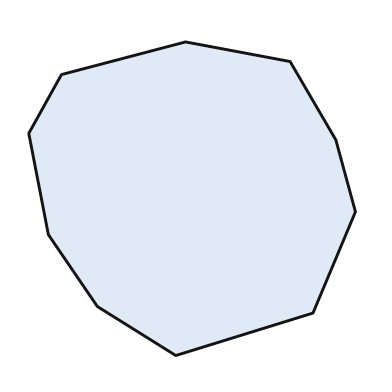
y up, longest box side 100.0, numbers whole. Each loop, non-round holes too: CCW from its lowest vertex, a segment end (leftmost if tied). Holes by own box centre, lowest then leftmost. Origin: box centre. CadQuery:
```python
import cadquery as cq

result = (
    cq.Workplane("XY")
    .moveTo(-5.0, -48.0)
    .lineTo(37.0, -35.0)
    .lineTo(50.0, -4.0)
    .lineTo(44.0, 18.0)
    .lineTo(30.0, 42.0)
    .lineTo(-2.0, 48.0)
    .lineTo(-40.0, 38.0)
    .lineTo(-50.0, 20.0)
    .lineTo(-44.0, -11.0)
    .lineTo(-29.0, -33.0)
    .close()
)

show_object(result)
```